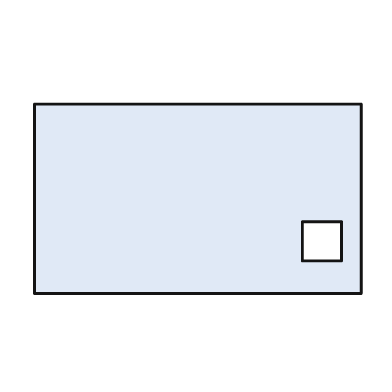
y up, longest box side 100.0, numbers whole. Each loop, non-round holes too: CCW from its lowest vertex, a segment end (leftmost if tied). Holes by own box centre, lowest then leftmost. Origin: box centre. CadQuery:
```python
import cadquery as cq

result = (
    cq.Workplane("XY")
    .moveTo(-50.0, -29.0)
    .lineTo(50.0, -29.0)
    .lineTo(50.0, 29.0)
    .lineTo(-50.0, 29.0)
    .close()
    .moveTo(32.0, -19.0)
    .lineTo(44.0, -19.0)
    .lineTo(44.0, -7.0)
    .lineTo(32.0, -7.0)
    .close()
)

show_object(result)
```